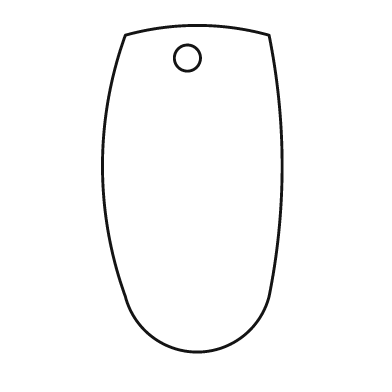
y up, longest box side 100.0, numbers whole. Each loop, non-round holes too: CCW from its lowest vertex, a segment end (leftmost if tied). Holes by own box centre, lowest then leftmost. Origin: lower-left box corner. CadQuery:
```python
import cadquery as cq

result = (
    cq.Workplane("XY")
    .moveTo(7.0, 17.0)
    .threePointArc((29.0, 0.0), (51.0, 17.0))
    .threePointArc((55.0, 57.0), (51.0, 97.0))
    .threePointArc((29.0, 100.0), (7.0, 97.0))
    .threePointArc((0.0, 57.0), (7.0, 17.0))
    .close()
    .moveTo(26.0, 90.0)
    .circle(4.0)
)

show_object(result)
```